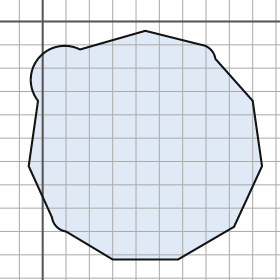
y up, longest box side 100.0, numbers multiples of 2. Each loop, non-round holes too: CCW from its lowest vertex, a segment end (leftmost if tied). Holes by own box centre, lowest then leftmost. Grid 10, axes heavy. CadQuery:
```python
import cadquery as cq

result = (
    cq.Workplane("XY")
    .moveTo(30.0, -102.0)
    .lineTo(58.0, -102.0)
    .lineTo(82.0, -88.0)
    .lineTo(94.0, -62.0)
    .lineTo(90.0, -34.0)
    .lineTo(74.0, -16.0)
    .threePointArc((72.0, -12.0), (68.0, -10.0))
    .lineTo(44.0, -4.0)
    .lineTo(16.0, -12.0)
    .threePointArc((-2.0, -16.0), (-2.0, -34.0))
    .lineTo(-6.0, -62.0)
    .lineTo(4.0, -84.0)
    .threePointArc((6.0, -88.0), (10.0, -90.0))
    .close()
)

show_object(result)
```